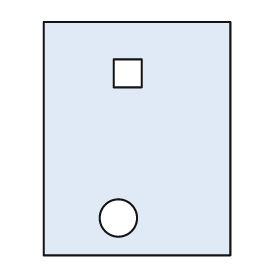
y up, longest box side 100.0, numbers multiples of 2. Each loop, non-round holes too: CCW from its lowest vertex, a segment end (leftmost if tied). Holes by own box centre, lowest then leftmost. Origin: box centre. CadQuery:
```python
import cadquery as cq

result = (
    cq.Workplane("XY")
    .moveTo(-40.0, -50.0)
    .lineTo(40.0, -50.0)
    .lineTo(40.0, 50.0)
    .lineTo(-40.0, 50.0)
    .close()
    .moveTo(-8.0, -34.0)
    .circle(8.0)
    .moveTo(-10.0, 22.0)
    .lineTo(2.0, 22.0)
    .lineTo(2.0, 34.0)
    .lineTo(-10.0, 34.0)
    .close()
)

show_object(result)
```